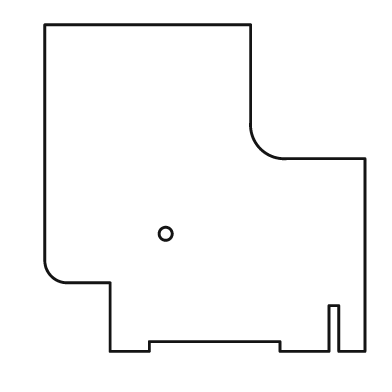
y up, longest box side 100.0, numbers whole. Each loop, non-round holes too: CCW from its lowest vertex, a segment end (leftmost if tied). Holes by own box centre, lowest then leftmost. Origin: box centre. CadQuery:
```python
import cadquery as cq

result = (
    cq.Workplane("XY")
    .moveTo(-29.0, -50.0)
    .lineTo(-17.0, -50.0)
    .lineTo(-17.0, -47.0)
    .lineTo(23.0, -47.0)
    .lineTo(23.0, -50.0)
    .lineTo(38.0, -50.0)
    .lineTo(38.0, -36.0)
    .lineTo(41.0, -36.0)
    .lineTo(41.0, -50.0)
    .lineTo(49.0, -50.0)
    .lineTo(49.0, 9.0)
    .lineTo(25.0, 9.0)
    .threePointArc((17.0, 12.0), (14.0, 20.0))
    .lineTo(14.0, 50.0)
    .lineTo(-49.0, 50.0)
    .lineTo(-49.0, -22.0)
    .threePointArc((-47.0, -27.0), (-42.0, -29.0))
    .lineTo(-29.0, -29.0)
    .close()
    .moveTo(-12.0, -14.0)
    .circle(2.0)
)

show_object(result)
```